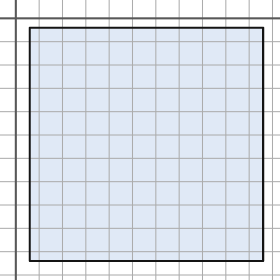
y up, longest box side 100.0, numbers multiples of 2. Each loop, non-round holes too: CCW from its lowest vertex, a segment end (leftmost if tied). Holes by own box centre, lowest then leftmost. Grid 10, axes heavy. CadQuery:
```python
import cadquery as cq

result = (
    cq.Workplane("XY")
    .moveTo(6.0, -104.0)
    .lineTo(106.0, -104.0)
    .lineTo(106.0, -4.0)
    .lineTo(6.0, -4.0)
    .close()
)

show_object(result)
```